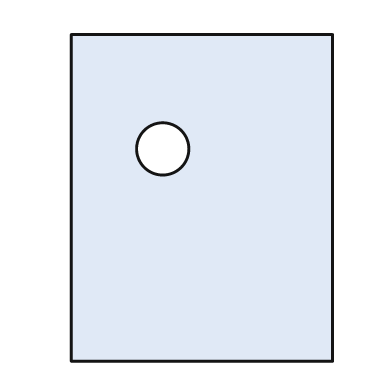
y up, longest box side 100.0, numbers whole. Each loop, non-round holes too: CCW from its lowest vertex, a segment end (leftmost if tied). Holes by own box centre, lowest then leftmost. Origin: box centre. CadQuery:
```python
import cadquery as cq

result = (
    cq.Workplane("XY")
    .moveTo(-40.0, -50.0)
    .lineTo(40.0, -50.0)
    .lineTo(40.0, 50.0)
    .lineTo(-40.0, 50.0)
    .close()
    .moveTo(-12.0, 15.0)
    .circle(8.0)
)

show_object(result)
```